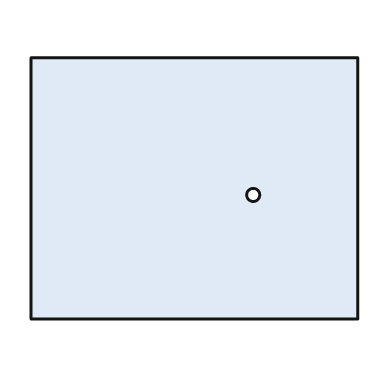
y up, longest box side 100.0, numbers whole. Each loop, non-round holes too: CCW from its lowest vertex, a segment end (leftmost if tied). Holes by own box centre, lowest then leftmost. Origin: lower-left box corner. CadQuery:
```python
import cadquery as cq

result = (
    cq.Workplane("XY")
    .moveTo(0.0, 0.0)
    .lineTo(100.0, 0.0)
    .lineTo(100.0, 80.0)
    .lineTo(0.0, 80.0)
    .close()
    .moveTo(68.0, 38.0)
    .circle(2.0)
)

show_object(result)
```